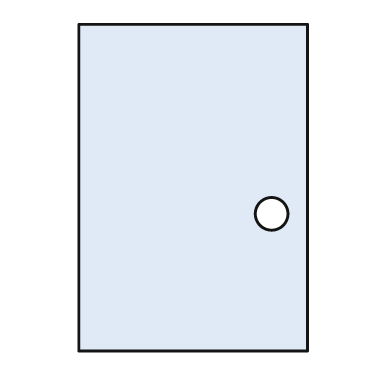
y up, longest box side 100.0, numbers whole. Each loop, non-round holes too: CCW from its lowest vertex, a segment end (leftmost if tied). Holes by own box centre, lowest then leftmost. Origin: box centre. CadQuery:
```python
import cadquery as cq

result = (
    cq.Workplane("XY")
    .moveTo(-35.0, -50.0)
    .lineTo(35.0, -50.0)
    .lineTo(35.0, 50.0)
    .lineTo(-35.0, 50.0)
    .close()
    .moveTo(24.0, -8.0)
    .circle(5.0)
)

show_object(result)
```